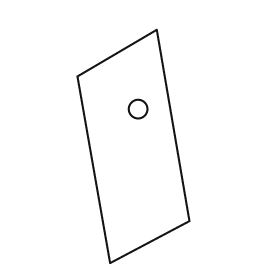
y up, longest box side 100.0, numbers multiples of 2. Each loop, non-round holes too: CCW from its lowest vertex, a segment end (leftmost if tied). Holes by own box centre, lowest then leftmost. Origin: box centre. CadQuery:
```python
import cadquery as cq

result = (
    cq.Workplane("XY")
    .moveTo(-10.0, -50.0)
    .lineTo(24.0, -32.0)
    .lineTo(10.0, 50.0)
    .lineTo(-24.0, 30.0)
    .close()
    .moveTo(2.0, 16.0)
    .circle(4.0)
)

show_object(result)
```